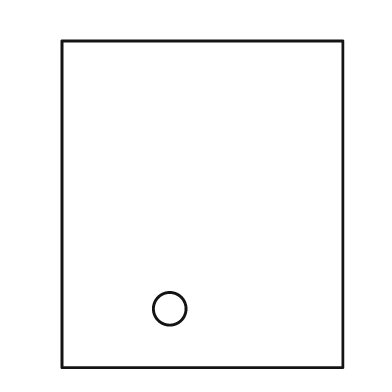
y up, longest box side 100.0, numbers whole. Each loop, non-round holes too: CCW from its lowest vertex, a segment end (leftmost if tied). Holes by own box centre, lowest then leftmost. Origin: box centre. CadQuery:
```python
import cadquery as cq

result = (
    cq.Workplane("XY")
    .moveTo(-43.0, -50.0)
    .lineTo(43.0, -50.0)
    .lineTo(43.0, 50.0)
    .lineTo(-43.0, 50.0)
    .close()
    .moveTo(-10.0, -32.0)
    .circle(5.0)
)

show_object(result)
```